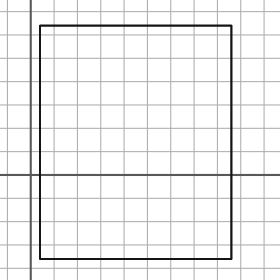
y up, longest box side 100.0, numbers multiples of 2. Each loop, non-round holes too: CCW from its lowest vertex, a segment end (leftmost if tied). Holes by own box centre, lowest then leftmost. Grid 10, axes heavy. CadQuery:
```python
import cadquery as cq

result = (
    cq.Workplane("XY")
    .moveTo(4.0, -36.0)
    .lineTo(86.0, -36.0)
    .lineTo(86.0, 64.0)
    .lineTo(4.0, 64.0)
    .close()
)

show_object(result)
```